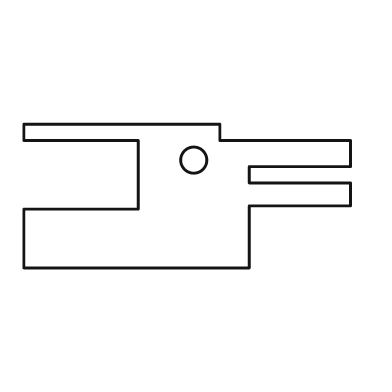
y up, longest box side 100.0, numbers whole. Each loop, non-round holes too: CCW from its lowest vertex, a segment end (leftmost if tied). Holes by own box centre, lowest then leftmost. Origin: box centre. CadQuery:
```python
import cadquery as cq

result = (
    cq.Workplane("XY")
    .moveTo(-50.0, -22.0)
    .lineTo(19.0, -22.0)
    .lineTo(19.0, -3.0)
    .lineTo(50.0, -3.0)
    .lineTo(50.0, 4.0)
    .lineTo(19.0, 4.0)
    .lineTo(19.0, 9.0)
    .lineTo(50.0, 9.0)
    .lineTo(50.0, 17.0)
    .lineTo(10.0, 17.0)
    .lineTo(10.0, 22.0)
    .lineTo(-50.0, 22.0)
    .lineTo(-50.0, 17.0)
    .lineTo(-15.0, 17.0)
    .lineTo(-15.0, -4.0)
    .lineTo(-50.0, -4.0)
    .close()
    .moveTo(2.0, 11.0)
    .circle(4.0)
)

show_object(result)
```